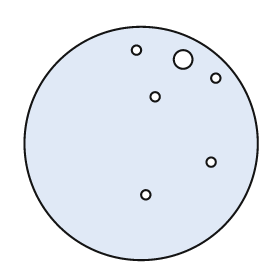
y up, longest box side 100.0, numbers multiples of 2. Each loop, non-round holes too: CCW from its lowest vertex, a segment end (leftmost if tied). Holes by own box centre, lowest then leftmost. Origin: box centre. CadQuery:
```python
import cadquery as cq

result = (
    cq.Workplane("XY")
    .moveTo(0.0, 0.0)
    .circle(50.0)
    .moveTo(2.0, -22.0)
    .circle(2.0)
    .moveTo(30.0, -8.0)
    .circle(2.0)
    .moveTo(6.0, 20.0)
    .circle(2.0)
    .moveTo(32.0, 28.0)
    .circle(2.0)
    .moveTo(18.0, 36.0)
    .circle(4.0)
    .moveTo(-2.0, 40.0)
    .circle(2.0)
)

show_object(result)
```